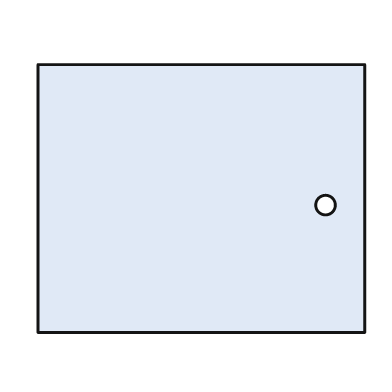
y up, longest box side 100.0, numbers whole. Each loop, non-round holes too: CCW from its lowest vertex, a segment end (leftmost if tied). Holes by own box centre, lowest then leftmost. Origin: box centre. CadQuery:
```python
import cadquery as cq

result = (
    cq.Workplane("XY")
    .moveTo(-50.0, -41.0)
    .lineTo(50.0, -41.0)
    .lineTo(50.0, 41.0)
    .lineTo(-50.0, 41.0)
    .close()
    .moveTo(38.0, -2.0)
    .circle(3.0)
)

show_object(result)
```